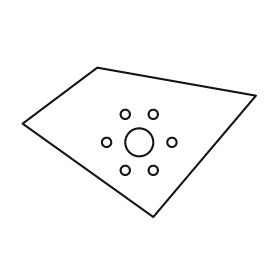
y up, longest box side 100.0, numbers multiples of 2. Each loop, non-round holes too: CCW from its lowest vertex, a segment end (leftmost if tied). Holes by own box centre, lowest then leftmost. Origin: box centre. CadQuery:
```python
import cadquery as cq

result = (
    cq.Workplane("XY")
    .moveTo(6.0, -32.0)
    .lineTo(50.0, 20.0)
    .lineTo(-18.0, 32.0)
    .lineTo(-50.0, 8.0)
    .close()
    .moveTo(-6.0, -12.0)
    .circle(2.0)
    .moveTo(6.0, -12.0)
    .circle(2.0)
    .moveTo(-14.0, 0.0)
    .circle(2.0)
    .moveTo(0.0, 0.0)
    .circle(6.0)
    .moveTo(14.0, 0.0)
    .circle(2.0)
    .moveTo(-6.0, 12.0)
    .circle(2.0)
    .moveTo(6.0, 12.0)
    .circle(2.0)
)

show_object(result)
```